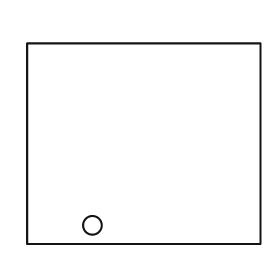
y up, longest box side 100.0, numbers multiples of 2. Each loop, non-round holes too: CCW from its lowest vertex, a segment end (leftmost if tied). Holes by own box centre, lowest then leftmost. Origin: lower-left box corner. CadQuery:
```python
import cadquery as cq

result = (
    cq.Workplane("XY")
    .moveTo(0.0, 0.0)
    .lineTo(100.0, 0.0)
    .lineTo(100.0, 86.0)
    .lineTo(0.0, 86.0)
    .close()
    .moveTo(28.0, 8.0)
    .circle(4.0)
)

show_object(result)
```